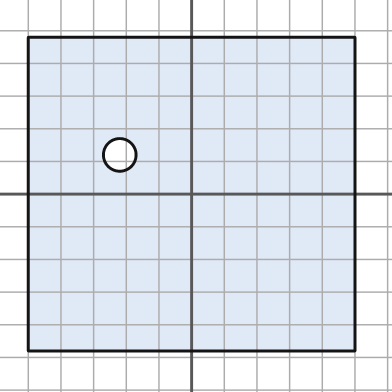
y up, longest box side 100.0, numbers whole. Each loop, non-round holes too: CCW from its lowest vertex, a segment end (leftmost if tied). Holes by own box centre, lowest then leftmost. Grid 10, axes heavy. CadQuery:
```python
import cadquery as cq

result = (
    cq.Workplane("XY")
    .moveTo(-50.0, -48.0)
    .lineTo(50.0, -48.0)
    .lineTo(50.0, 48.0)
    .lineTo(-50.0, 48.0)
    .close()
    .moveTo(-22.0, 12.0)
    .circle(5.0)
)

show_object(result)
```